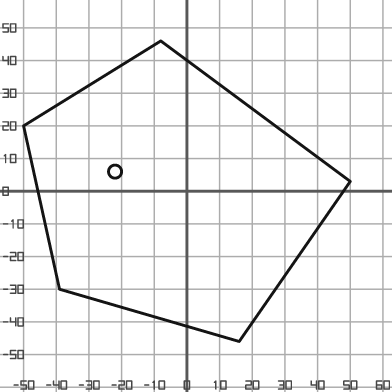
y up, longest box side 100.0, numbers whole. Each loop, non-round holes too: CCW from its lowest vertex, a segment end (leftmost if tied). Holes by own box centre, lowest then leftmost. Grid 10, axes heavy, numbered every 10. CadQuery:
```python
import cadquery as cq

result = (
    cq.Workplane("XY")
    .moveTo(16.0, -46.0)
    .lineTo(50.0, 3.0)
    .lineTo(-8.0, 46.0)
    .lineTo(-50.0, 20.0)
    .lineTo(-39.0, -30.0)
    .close()
    .moveTo(-22.0, 6.0)
    .circle(2.0)
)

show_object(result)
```